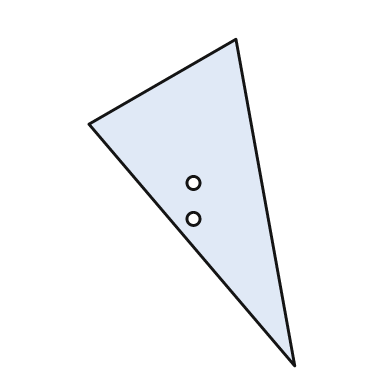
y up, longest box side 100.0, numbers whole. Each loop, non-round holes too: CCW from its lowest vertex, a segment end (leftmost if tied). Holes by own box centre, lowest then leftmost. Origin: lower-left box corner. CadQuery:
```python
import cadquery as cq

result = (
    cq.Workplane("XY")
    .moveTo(63.0, 0.0)
    .lineTo(45.0, 100.0)
    .lineTo(0.0, 74.0)
    .close()
    .moveTo(32.0, 45.0)
    .circle(2.0)
    .moveTo(32.0, 56.0)
    .circle(2.0)
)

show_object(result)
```